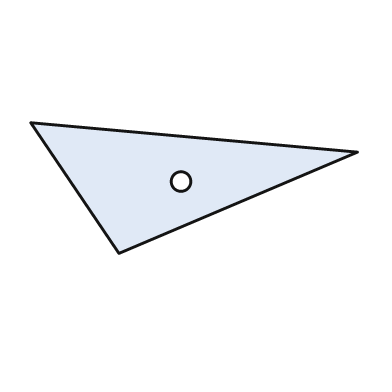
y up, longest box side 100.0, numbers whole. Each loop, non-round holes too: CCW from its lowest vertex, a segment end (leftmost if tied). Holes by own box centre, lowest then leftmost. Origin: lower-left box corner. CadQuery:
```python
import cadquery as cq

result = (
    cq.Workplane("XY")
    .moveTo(27.0, 0.0)
    .lineTo(100.0, 31.0)
    .lineTo(0.0, 40.0)
    .close()
    .moveTo(46.0, 22.0)
    .circle(3.0)
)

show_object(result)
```